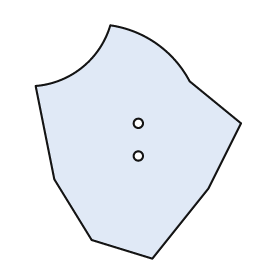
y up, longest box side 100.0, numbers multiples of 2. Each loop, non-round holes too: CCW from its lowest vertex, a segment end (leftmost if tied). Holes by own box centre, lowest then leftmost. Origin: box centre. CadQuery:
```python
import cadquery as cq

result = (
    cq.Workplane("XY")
    .moveTo(6.0, -50.0)
    .lineTo(30.0, -20.0)
    .lineTo(44.0, 8.0)
    .lineTo(22.0, 26.0)
    .threePointArc((8.0, 42.0), (-12.0, 50.0))
    .threePointArc((-24.0, 32.0), (-44.0, 24.0))
    .lineTo(-36.0, -16.0)
    .lineTo(-20.0, -42.0)
    .close()
    .moveTo(0.0, -6.0)
    .circle(2.0)
    .moveTo(0.0, 8.0)
    .circle(2.0)
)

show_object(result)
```